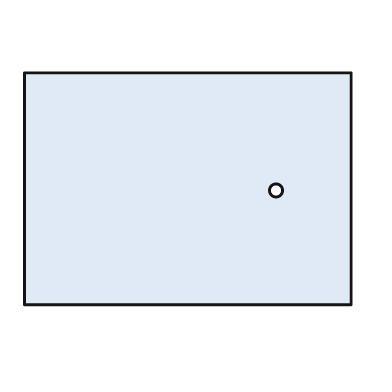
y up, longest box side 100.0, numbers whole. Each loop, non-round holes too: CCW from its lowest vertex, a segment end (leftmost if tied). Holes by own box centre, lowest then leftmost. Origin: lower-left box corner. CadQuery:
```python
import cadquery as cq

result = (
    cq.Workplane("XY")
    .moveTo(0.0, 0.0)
    .lineTo(100.0, 0.0)
    .lineTo(100.0, 71.0)
    .lineTo(0.0, 71.0)
    .close()
    .moveTo(77.0, 35.0)
    .circle(2.0)
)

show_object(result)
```